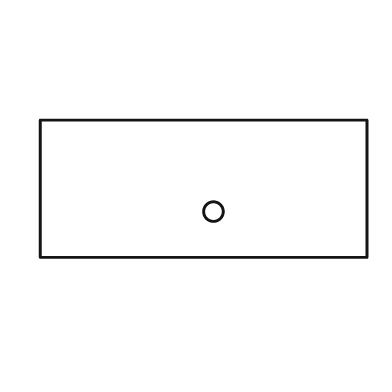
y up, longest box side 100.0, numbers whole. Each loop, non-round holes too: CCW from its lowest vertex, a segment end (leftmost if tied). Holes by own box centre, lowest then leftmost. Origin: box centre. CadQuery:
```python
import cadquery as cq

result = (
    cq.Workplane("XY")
    .moveTo(-50.0, -21.0)
    .lineTo(50.0, -21.0)
    .lineTo(50.0, 21.0)
    .lineTo(-50.0, 21.0)
    .close()
    .moveTo(3.0, -7.0)
    .circle(3.0)
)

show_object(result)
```